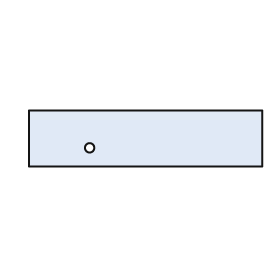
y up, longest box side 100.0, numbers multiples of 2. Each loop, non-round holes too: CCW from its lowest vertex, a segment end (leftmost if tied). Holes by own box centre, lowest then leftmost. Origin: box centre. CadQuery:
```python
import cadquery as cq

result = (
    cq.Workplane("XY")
    .moveTo(-50.0, -12.0)
    .lineTo(50.0, -12.0)
    .lineTo(50.0, 12.0)
    .lineTo(-50.0, 12.0)
    .close()
    .moveTo(-24.0, -4.0)
    .circle(2.0)
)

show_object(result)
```